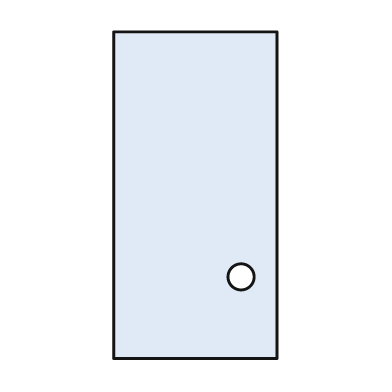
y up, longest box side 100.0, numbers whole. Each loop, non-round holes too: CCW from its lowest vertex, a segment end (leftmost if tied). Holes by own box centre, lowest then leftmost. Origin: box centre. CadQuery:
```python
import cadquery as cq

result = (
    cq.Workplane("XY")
    .moveTo(-25.0, -50.0)
    .lineTo(25.0, -50.0)
    .lineTo(25.0, 50.0)
    .lineTo(-25.0, 50.0)
    .close()
    .moveTo(14.0, -25.0)
    .circle(4.0)
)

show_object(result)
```